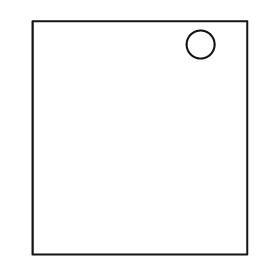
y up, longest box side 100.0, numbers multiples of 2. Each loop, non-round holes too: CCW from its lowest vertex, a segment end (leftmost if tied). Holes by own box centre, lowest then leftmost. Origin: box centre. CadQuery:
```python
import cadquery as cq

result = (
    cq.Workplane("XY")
    .moveTo(-46.0, -50.0)
    .lineTo(46.0, -50.0)
    .lineTo(46.0, 50.0)
    .lineTo(-46.0, 50.0)
    .close()
    .moveTo(26.0, 40.0)
    .circle(6.0)
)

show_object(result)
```